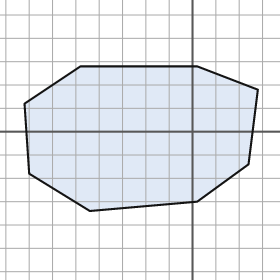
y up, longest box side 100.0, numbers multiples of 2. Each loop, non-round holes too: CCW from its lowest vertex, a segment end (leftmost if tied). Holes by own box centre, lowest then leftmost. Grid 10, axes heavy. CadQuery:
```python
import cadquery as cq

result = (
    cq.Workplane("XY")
    .moveTo(-44.0, -34.0)
    .lineTo(2.0, -30.0)
    .lineTo(24.0, -14.0)
    .lineTo(28.0, 18.0)
    .lineTo(2.0, 28.0)
    .lineTo(-48.0, 28.0)
    .lineTo(-72.0, 12.0)
    .lineTo(-70.0, -18.0)
    .close()
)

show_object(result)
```